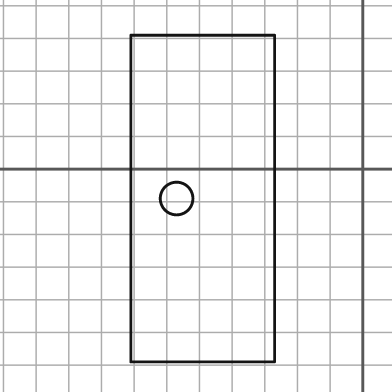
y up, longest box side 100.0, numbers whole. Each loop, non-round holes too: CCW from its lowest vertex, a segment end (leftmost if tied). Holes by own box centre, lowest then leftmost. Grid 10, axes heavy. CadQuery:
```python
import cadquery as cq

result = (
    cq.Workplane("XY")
    .moveTo(-71.0, -59.0)
    .lineTo(-27.0, -59.0)
    .lineTo(-27.0, 41.0)
    .lineTo(-71.0, 41.0)
    .close()
    .moveTo(-57.0, -9.0)
    .circle(5.0)
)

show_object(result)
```